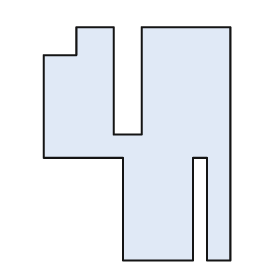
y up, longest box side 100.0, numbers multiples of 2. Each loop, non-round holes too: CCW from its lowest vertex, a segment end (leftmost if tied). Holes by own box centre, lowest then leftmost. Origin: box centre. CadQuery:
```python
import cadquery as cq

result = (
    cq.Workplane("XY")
    .moveTo(-6.0, -50.0)
    .lineTo(24.0, -50.0)
    .lineTo(24.0, -6.0)
    .lineTo(30.0, -6.0)
    .lineTo(30.0, -50.0)
    .lineTo(40.0, -50.0)
    .lineTo(40.0, 50.0)
    .lineTo(2.0, 50.0)
    .lineTo(2.0, 4.0)
    .lineTo(-10.0, 4.0)
    .lineTo(-10.0, 50.0)
    .lineTo(-26.0, 50.0)
    .lineTo(-26.0, 38.0)
    .lineTo(-40.0, 38.0)
    .lineTo(-40.0, -6.0)
    .lineTo(-6.0, -6.0)
    .close()
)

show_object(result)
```